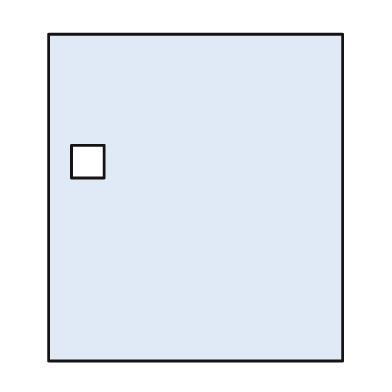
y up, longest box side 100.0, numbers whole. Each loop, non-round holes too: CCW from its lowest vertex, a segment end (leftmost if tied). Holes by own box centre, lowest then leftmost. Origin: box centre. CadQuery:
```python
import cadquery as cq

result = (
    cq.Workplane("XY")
    .moveTo(-45.0, -50.0)
    .lineTo(45.0, -50.0)
    .lineTo(45.0, 50.0)
    .lineTo(-45.0, 50.0)
    .close()
    .moveTo(-38.0, 6.0)
    .lineTo(-28.0, 6.0)
    .lineTo(-28.0, 16.0)
    .lineTo(-38.0, 16.0)
    .close()
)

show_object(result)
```